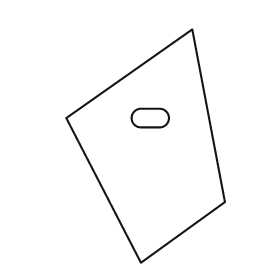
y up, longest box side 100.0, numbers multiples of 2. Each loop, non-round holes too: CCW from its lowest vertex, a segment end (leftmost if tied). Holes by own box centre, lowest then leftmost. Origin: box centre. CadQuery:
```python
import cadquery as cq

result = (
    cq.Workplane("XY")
    .moveTo(-2.0, -50.0)
    .lineTo(34.0, -24.0)
    .lineTo(20.0, 50.0)
    .lineTo(-34.0, 12.0)
    .close()
    .moveTo(-2.0, 8.0)
    .lineTo(6.0, 8.0)
    .threePointArc((10.0, 12.0), (6.0, 16.0))
    .lineTo(-2.0, 16.0)
    .threePointArc((-6.0, 12.0), (-2.0, 8.0))
    .close()
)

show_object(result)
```